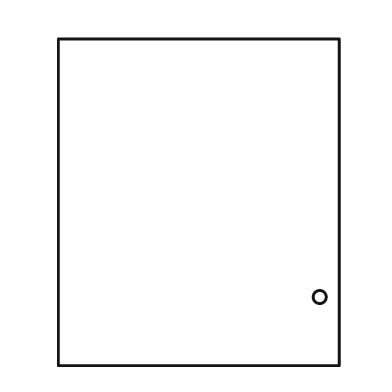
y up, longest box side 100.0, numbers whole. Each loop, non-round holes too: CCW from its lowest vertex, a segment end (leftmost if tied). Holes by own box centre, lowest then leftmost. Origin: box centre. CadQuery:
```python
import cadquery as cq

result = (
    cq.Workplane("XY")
    .moveTo(-43.0, -50.0)
    .lineTo(43.0, -50.0)
    .lineTo(43.0, 50.0)
    .lineTo(-43.0, 50.0)
    .close()
    .moveTo(37.0, -29.0)
    .circle(2.0)
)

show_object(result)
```